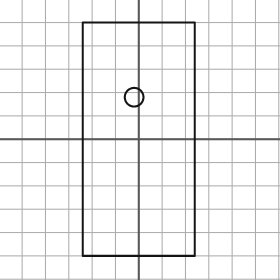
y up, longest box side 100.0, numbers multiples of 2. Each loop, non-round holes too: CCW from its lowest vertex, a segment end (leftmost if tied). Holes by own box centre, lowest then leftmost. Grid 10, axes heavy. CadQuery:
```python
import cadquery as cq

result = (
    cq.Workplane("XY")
    .moveTo(-24.0, -50.0)
    .lineTo(24.0, -50.0)
    .lineTo(24.0, 50.0)
    .lineTo(-24.0, 50.0)
    .close()
    .moveTo(-2.0, 18.0)
    .circle(4.0)
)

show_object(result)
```